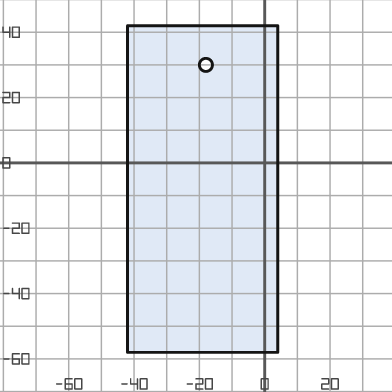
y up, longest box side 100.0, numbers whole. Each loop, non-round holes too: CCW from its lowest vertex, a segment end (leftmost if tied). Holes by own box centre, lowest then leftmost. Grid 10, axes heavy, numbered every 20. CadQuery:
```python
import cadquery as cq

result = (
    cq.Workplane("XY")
    .moveTo(-42.0, -58.0)
    .lineTo(4.0, -58.0)
    .lineTo(4.0, 42.0)
    .lineTo(-42.0, 42.0)
    .close()
    .moveTo(-18.0, 30.0)
    .circle(2.0)
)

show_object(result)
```